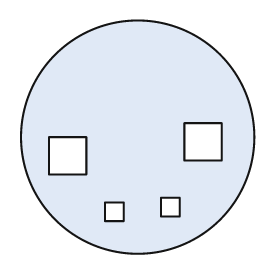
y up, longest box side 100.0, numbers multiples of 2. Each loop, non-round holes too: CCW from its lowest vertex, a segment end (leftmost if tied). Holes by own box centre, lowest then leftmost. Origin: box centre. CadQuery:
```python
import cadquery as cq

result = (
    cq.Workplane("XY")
    .moveTo(0.0, 0.0)
    .circle(50.0)
    .moveTo(-14.0, -36.0)
    .lineTo(-6.0, -36.0)
    .lineTo(-6.0, -28.0)
    .lineTo(-14.0, -28.0)
    .close()
    .moveTo(10.0, -34.0)
    .lineTo(18.0, -34.0)
    .lineTo(18.0, -26.0)
    .lineTo(10.0, -26.0)
    .close()
    .moveTo(-38.0, -16.0)
    .lineTo(-22.0, -16.0)
    .lineTo(-22.0, 0.0)
    .lineTo(-38.0, 0.0)
    .close()
    .moveTo(20.0, -10.0)
    .lineTo(36.0, -10.0)
    .lineTo(36.0, 6.0)
    .lineTo(20.0, 6.0)
    .close()
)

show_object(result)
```